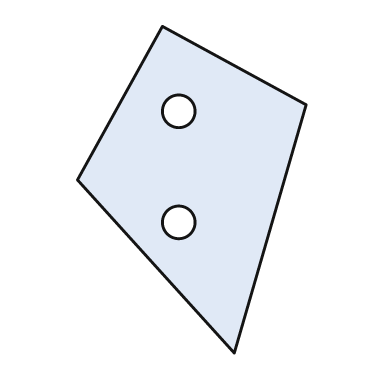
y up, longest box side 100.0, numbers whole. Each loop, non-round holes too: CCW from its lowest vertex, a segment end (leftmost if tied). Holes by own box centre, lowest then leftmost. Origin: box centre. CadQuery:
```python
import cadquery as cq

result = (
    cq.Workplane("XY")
    .moveTo(13.0, -50.0)
    .lineTo(35.0, 26.0)
    .lineTo(-9.0, 50.0)
    .lineTo(-35.0, 3.0)
    .close()
    .moveTo(-4.0, -10.0)
    .circle(5.0)
    .moveTo(-4.0, 24.0)
    .circle(5.0)
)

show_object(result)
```